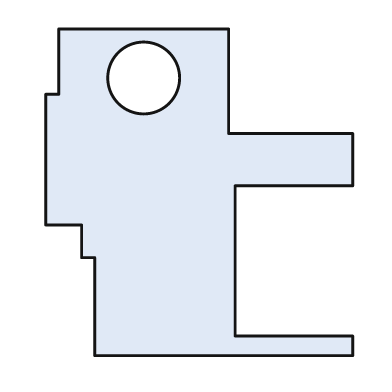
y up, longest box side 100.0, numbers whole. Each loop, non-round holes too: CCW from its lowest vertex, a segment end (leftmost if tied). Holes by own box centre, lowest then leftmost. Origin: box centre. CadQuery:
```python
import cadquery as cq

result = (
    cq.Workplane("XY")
    .moveTo(-32.0, -50.0)
    .lineTo(47.0, -50.0)
    .lineTo(47.0, -44.0)
    .lineTo(11.0, -44.0)
    .lineTo(11.0, 2.0)
    .lineTo(47.0, 2.0)
    .lineTo(47.0, 18.0)
    .lineTo(9.0, 18.0)
    .lineTo(9.0, 50.0)
    .lineTo(-43.0, 50.0)
    .lineTo(-43.0, 30.0)
    .lineTo(-47.0, 30.0)
    .lineTo(-47.0, -10.0)
    .lineTo(-36.0, -10.0)
    .lineTo(-36.0, -20.0)
    .lineTo(-32.0, -20.0)
    .close()
    .moveTo(-17.0, 35.0)
    .circle(11.0)
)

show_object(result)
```